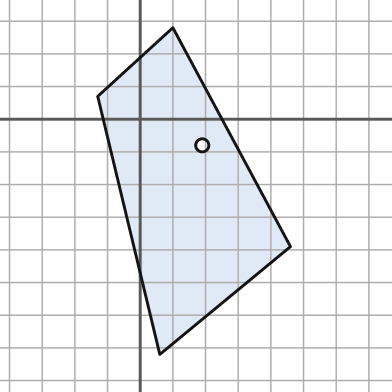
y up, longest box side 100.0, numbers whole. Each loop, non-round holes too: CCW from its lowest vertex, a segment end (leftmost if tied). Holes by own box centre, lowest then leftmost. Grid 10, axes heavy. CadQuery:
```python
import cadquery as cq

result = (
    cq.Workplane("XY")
    .moveTo(6.0, -72.0)
    .lineTo(46.0, -39.0)
    .lineTo(10.0, 28.0)
    .lineTo(-13.0, 7.0)
    .close()
    .moveTo(19.0, -8.0)
    .circle(2.0)
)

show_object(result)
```